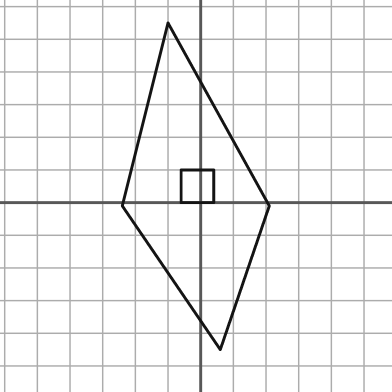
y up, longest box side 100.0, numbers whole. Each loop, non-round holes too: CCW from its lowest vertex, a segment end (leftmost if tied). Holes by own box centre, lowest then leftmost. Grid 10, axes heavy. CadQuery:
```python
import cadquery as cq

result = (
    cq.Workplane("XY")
    .moveTo(6.0, -45.0)
    .lineTo(21.0, -1.0)
    .lineTo(-10.0, 55.0)
    .lineTo(-24.0, -1.0)
    .close()
    .moveTo(-6.0, 0.0)
    .lineTo(4.0, 0.0)
    .lineTo(4.0, 10.0)
    .lineTo(-6.0, 10.0)
    .close()
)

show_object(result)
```